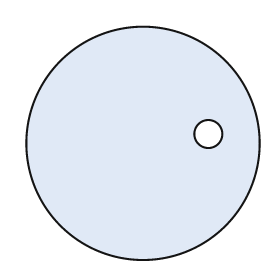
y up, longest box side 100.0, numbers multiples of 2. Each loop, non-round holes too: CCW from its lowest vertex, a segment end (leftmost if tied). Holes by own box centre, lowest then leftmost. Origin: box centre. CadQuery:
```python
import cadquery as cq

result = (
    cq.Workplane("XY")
    .moveTo(0.0, 0.0)
    .circle(50.0)
    .moveTo(28.0, 4.0)
    .circle(6.0)
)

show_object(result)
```